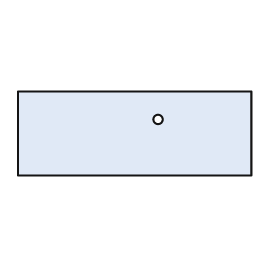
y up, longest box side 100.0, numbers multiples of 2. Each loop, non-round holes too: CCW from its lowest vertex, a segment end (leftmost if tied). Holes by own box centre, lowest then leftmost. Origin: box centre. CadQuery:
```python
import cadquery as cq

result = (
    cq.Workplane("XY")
    .moveTo(-50.0, -18.0)
    .lineTo(50.0, -18.0)
    .lineTo(50.0, 18.0)
    .lineTo(-50.0, 18.0)
    .close()
    .moveTo(10.0, 6.0)
    .circle(2.0)
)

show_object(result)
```